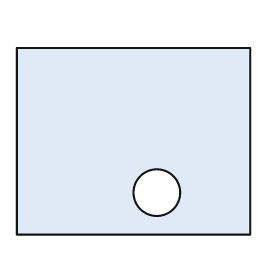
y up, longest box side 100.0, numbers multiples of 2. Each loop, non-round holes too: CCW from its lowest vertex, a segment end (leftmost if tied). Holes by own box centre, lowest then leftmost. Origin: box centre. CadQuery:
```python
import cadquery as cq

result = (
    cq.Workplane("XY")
    .moveTo(-50.0, -40.0)
    .lineTo(50.0, -40.0)
    .lineTo(50.0, 40.0)
    .lineTo(-50.0, 40.0)
    .close()
    .moveTo(10.0, -22.0)
    .circle(10.0)
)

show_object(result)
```